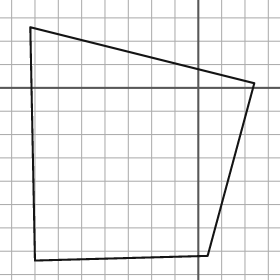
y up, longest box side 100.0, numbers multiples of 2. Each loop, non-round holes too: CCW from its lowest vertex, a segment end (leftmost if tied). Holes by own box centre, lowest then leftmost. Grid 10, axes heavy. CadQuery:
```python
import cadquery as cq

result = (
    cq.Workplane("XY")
    .moveTo(-70.0, -74.0)
    .lineTo(4.0, -72.0)
    .lineTo(24.0, 2.0)
    .lineTo(-72.0, 26.0)
    .close()
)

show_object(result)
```